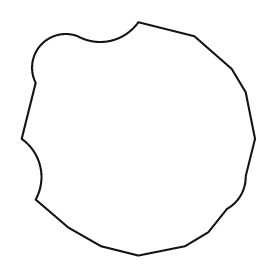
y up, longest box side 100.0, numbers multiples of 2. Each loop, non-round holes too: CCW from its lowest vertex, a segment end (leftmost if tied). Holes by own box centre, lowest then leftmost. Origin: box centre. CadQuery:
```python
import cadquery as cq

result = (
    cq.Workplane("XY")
    .moveTo(0.0, -50.0)
    .lineTo(20.0, -46.0)
    .lineTo(30.0, -40.0)
    .lineTo(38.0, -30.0)
    .threePointArc((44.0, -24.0), (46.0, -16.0))
    .lineTo(50.0, 0.0)
    .lineTo(46.0, 20.0)
    .lineTo(40.0, 30.0)
    .lineTo(24.0, 44.0)
    .lineTo(0.0, 50.0)
    .threePointArc((-12.0, 42.0), (-26.0, 44.0))
    .threePointArc((-42.0, 40.0), (-44.0, 24.0))
    .lineTo(-50.0, 0.0)
    .threePointArc((-42.0, -12.0), (-44.0, -26.0))
    .lineTo(-30.0, -38.0)
    .lineTo(-16.0, -46.0)
    .close()
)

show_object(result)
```